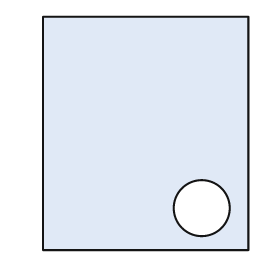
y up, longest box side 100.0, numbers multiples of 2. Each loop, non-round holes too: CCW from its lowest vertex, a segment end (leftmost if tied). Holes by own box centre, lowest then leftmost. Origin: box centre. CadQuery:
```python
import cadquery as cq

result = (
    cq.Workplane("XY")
    .moveTo(-44.0, -50.0)
    .lineTo(44.0, -50.0)
    .lineTo(44.0, 50.0)
    .lineTo(-44.0, 50.0)
    .close()
    .moveTo(24.0, -32.0)
    .circle(12.0)
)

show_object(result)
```